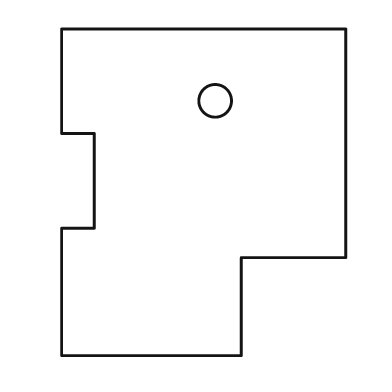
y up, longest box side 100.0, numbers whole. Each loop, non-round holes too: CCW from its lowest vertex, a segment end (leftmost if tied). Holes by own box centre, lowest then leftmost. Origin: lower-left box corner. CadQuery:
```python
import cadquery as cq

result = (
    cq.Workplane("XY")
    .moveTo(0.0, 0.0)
    .lineTo(55.0, 0.0)
    .lineTo(55.0, 30.0)
    .lineTo(87.0, 30.0)
    .lineTo(87.0, 100.0)
    .lineTo(0.0, 100.0)
    .lineTo(0.0, 68.0)
    .lineTo(10.0, 68.0)
    .lineTo(10.0, 39.0)
    .lineTo(0.0, 39.0)
    .close()
    .moveTo(47.0, 78.0)
    .circle(5.0)
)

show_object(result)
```